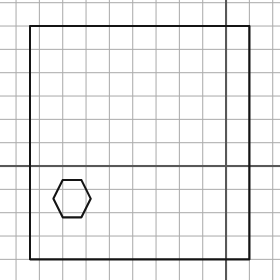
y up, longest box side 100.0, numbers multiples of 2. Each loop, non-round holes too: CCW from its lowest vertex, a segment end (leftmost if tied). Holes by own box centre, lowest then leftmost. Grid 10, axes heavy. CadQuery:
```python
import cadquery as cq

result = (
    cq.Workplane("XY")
    .moveTo(-84.0, -40.0)
    .lineTo(10.0, -40.0)
    .lineTo(10.0, 60.0)
    .lineTo(-84.0, 60.0)
    .close()
    .moveTo(-70.0, -22.0)
    .lineTo(-62.0, -22.0)
    .lineTo(-58.0, -14.0)
    .lineTo(-62.0, -6.0)
    .lineTo(-70.0, -6.0)
    .lineTo(-74.0, -14.0)
    .close()
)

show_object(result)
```